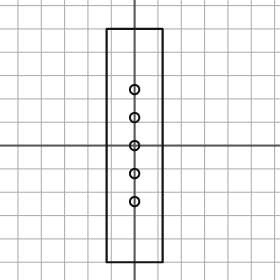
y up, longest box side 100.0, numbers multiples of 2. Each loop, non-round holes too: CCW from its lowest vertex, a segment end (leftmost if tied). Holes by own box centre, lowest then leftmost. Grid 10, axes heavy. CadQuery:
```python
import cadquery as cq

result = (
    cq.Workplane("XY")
    .moveTo(-12.0, -50.0)
    .lineTo(12.0, -50.0)
    .lineTo(12.0, 50.0)
    .lineTo(-12.0, 50.0)
    .close()
    .moveTo(0.0, -24.0)
    .circle(2.0)
    .moveTo(0.0, -12.0)
    .circle(2.0)
    .moveTo(0.0, 0.0)
    .circle(2.0)
    .moveTo(0.0, 12.0)
    .circle(2.0)
    .moveTo(0.0, 24.0)
    .circle(2.0)
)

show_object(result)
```